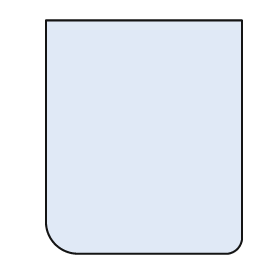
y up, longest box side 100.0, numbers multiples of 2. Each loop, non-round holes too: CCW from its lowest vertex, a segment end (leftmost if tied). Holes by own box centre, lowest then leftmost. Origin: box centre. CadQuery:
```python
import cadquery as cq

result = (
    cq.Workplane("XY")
    .moveTo(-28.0, -50.0)
    .lineTo(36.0, -50.0)
    .threePointArc((40.0, -48.0), (42.0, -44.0))
    .lineTo(42.0, 50.0)
    .lineTo(-42.0, 50.0)
    .lineTo(-42.0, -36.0)
    .threePointArc((-38.0, -46.0), (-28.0, -50.0))
    .close()
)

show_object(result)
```